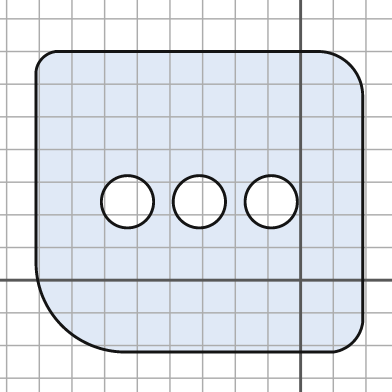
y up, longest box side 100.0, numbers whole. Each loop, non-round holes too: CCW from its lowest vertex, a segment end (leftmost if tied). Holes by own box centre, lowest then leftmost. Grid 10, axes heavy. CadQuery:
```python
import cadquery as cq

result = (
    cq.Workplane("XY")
    .moveTo(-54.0, -22.0)
    .lineTo(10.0, -22.0)
    .threePointArc((16.0, -19.0), (19.0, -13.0))
    .lineTo(19.0, 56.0)
    .threePointArc((15.0, 66.0), (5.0, 70.0))
    .lineTo(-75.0, 70.0)
    .threePointArc((-79.0, 68.0), (-81.0, 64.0))
    .lineTo(-81.0, 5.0)
    .threePointArc((-73.0, -14.0), (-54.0, -22.0))
    .close()
    .moveTo(-53.0, 24.0)
    .circle(8.0)
    .moveTo(-31.0, 24.0)
    .circle(8.0)
    .moveTo(-9.0, 24.0)
    .circle(8.0)
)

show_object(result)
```